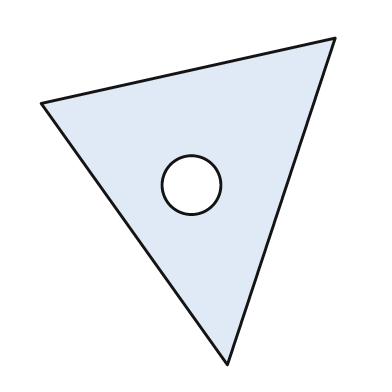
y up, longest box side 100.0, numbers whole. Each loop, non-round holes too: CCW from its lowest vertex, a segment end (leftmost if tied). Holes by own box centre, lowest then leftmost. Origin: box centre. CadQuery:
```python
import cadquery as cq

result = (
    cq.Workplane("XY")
    .moveTo(12.0, -50.0)
    .lineTo(45.0, 50.0)
    .lineTo(-45.0, 30.0)
    .close()
    .moveTo(1.0, 5.0)
    .circle(9.0)
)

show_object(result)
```